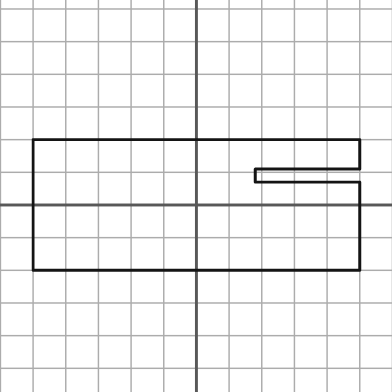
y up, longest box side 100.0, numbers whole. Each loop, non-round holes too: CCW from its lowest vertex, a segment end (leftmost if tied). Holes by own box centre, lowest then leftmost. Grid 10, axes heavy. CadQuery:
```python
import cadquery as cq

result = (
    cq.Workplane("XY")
    .moveTo(-50.0, -20.0)
    .lineTo(50.0, -20.0)
    .lineTo(50.0, 7.0)
    .lineTo(18.0, 7.0)
    .lineTo(18.0, 11.0)
    .lineTo(50.0, 11.0)
    .lineTo(50.0, 20.0)
    .lineTo(-50.0, 20.0)
    .close()
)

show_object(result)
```